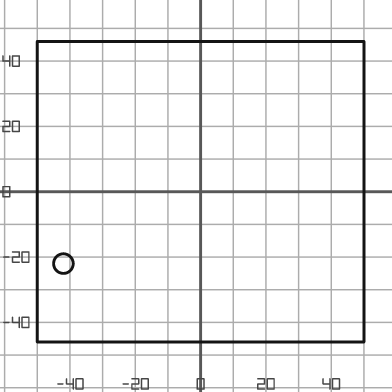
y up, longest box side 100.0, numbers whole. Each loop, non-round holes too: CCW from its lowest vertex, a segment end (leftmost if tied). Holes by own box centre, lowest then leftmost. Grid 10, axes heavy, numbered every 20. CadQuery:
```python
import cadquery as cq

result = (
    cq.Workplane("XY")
    .moveTo(-50.0, -46.0)
    .lineTo(50.0, -46.0)
    .lineTo(50.0, 46.0)
    .lineTo(-50.0, 46.0)
    .close()
    .moveTo(-42.0, -22.0)
    .circle(3.0)
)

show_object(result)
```